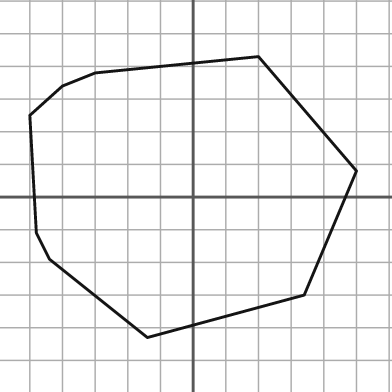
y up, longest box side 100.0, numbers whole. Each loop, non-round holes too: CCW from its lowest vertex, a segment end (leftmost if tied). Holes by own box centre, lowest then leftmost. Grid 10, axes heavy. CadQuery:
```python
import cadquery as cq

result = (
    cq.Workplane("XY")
    .moveTo(-14.0, -43.0)
    .lineTo(34.0, -30.0)
    .lineTo(50.0, 8.0)
    .lineTo(20.0, 43.0)
    .lineTo(-30.0, 38.0)
    .lineTo(-40.0, 34.0)
    .lineTo(-50.0, 25.0)
    .lineTo(-48.0, -11.0)
    .lineTo(-44.0, -19.0)
    .close()
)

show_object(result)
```